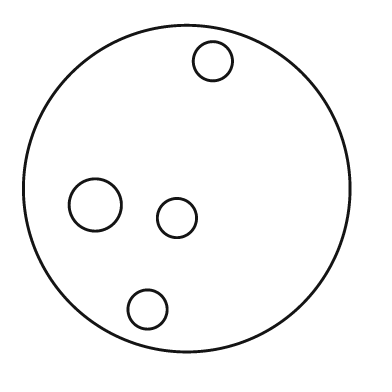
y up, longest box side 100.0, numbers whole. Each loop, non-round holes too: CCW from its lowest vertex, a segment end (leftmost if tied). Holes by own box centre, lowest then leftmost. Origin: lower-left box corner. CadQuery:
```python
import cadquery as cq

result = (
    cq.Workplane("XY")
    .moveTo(50.0, 50.0)
    .circle(50.0)
    .moveTo(38.0, 13.0)
    .circle(6.0)
    .moveTo(47.0, 41.0)
    .circle(6.0)
    .moveTo(22.0, 45.0)
    .circle(8.0)
    .moveTo(58.0, 89.0)
    .circle(6.0)
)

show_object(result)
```